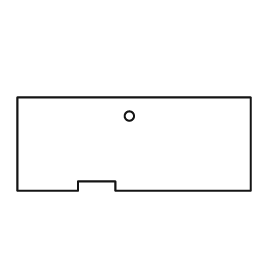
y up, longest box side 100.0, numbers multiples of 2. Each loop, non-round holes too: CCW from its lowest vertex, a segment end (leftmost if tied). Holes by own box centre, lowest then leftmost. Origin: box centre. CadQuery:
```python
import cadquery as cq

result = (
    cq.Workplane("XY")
    .moveTo(-50.0, -20.0)
    .lineTo(-24.0, -20.0)
    .lineTo(-24.0, -16.0)
    .lineTo(-8.0, -16.0)
    .lineTo(-8.0, -20.0)
    .lineTo(50.0, -20.0)
    .lineTo(50.0, 20.0)
    .lineTo(-50.0, 20.0)
    .close()
    .moveTo(-2.0, 12.0)
    .circle(2.0)
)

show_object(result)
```